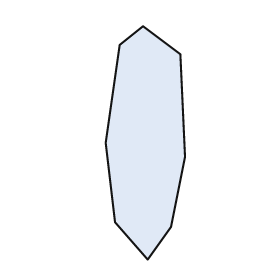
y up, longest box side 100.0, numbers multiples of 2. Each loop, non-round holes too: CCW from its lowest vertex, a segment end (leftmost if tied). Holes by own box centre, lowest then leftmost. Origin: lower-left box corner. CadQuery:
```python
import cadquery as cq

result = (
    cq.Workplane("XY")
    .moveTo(18.0, 0.0)
    .lineTo(28.0, 14.0)
    .lineTo(34.0, 44.0)
    .lineTo(32.0, 88.0)
    .lineTo(16.0, 100.0)
    .lineTo(6.0, 92.0)
    .lineTo(0.0, 50.0)
    .lineTo(4.0, 16.0)
    .close()
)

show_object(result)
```